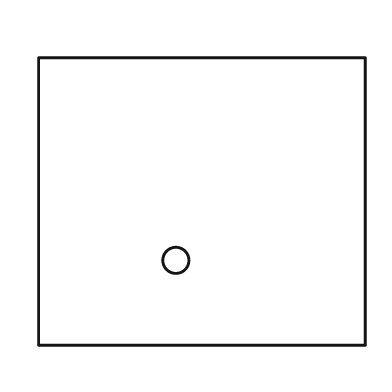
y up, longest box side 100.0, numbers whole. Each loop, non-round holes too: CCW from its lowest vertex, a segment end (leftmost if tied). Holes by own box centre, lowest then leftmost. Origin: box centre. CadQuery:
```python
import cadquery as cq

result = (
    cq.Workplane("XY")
    .moveTo(-50.0, -44.0)
    .lineTo(50.0, -44.0)
    .lineTo(50.0, 44.0)
    .lineTo(-50.0, 44.0)
    .close()
    .moveTo(-8.0, -18.0)
    .circle(4.0)
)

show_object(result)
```